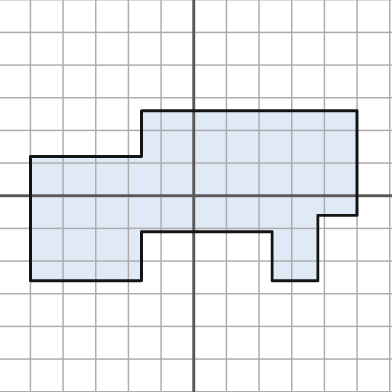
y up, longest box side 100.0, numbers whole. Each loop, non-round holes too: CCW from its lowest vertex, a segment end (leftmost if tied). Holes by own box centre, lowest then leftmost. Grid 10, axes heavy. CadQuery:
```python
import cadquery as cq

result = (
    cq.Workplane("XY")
    .moveTo(-50.0, -26.0)
    .lineTo(-16.0, -26.0)
    .lineTo(-16.0, -11.0)
    .lineTo(24.0, -11.0)
    .lineTo(24.0, -26.0)
    .lineTo(38.0, -26.0)
    .lineTo(38.0, -6.0)
    .lineTo(50.0, -6.0)
    .lineTo(50.0, 26.0)
    .lineTo(-16.0, 26.0)
    .lineTo(-16.0, 12.0)
    .lineTo(-50.0, 12.0)
    .close()
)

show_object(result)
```